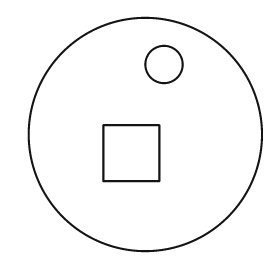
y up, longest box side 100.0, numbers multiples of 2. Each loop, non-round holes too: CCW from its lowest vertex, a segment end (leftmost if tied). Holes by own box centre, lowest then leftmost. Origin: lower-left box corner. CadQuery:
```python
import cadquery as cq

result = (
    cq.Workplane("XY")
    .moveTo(50.0, 50.0)
    .circle(50.0)
    .moveTo(32.0, 30.0)
    .lineTo(56.0, 30.0)
    .lineTo(56.0, 54.0)
    .lineTo(32.0, 54.0)
    .close()
    .moveTo(58.0, 80.0)
    .circle(8.0)
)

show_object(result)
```